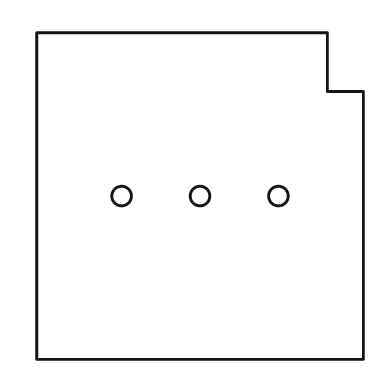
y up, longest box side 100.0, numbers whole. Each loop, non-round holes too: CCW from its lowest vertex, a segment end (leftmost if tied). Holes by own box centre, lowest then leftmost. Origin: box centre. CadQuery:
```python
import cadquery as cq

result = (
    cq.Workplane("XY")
    .moveTo(-50.0, -50.0)
    .lineTo(50.0, -50.0)
    .lineTo(50.0, 32.0)
    .lineTo(39.0, 32.0)
    .lineTo(39.0, 50.0)
    .lineTo(-50.0, 50.0)
    .close()
    .moveTo(-24.0, 0.0)
    .circle(3.0)
    .moveTo(0.0, 0.0)
    .circle(3.0)
    .moveTo(24.0, 0.0)
    .circle(3.0)
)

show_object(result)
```